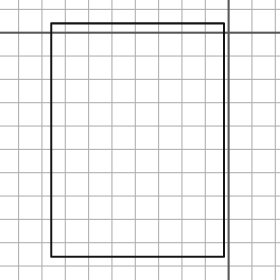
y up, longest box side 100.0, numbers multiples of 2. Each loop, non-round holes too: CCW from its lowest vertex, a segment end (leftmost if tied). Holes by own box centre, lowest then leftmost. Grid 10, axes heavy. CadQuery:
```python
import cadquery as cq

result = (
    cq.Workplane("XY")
    .moveTo(-76.0, -96.0)
    .lineTo(-2.0, -96.0)
    .lineTo(-2.0, 4.0)
    .lineTo(-76.0, 4.0)
    .close()
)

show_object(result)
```